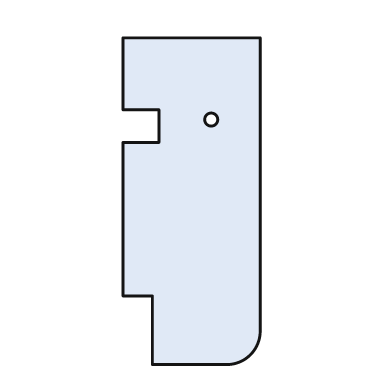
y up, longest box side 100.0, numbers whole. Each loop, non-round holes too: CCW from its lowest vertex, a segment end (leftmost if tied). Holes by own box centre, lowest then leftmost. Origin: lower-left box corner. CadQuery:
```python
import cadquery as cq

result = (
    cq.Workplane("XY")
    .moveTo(9.0, 0.0)
    .lineTo(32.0, 0.0)
    .threePointArc((39.0, 3.0), (42.0, 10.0))
    .lineTo(42.0, 100.0)
    .lineTo(0.0, 100.0)
    .lineTo(0.0, 78.0)
    .lineTo(11.0, 78.0)
    .lineTo(11.0, 68.0)
    .lineTo(0.0, 68.0)
    .lineTo(0.0, 21.0)
    .lineTo(9.0, 21.0)
    .close()
    .moveTo(27.0, 75.0)
    .circle(2.0)
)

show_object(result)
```